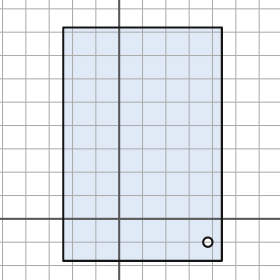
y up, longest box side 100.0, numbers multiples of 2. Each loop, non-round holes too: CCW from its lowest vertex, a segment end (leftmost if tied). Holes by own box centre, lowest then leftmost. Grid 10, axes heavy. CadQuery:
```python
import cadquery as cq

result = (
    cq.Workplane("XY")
    .moveTo(-24.0, -18.0)
    .lineTo(44.0, -18.0)
    .lineTo(44.0, 82.0)
    .lineTo(-24.0, 82.0)
    .close()
    .moveTo(38.0, -10.0)
    .circle(2.0)
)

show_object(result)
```